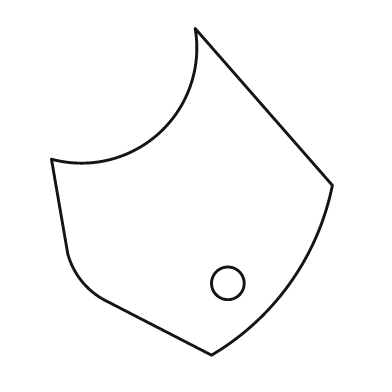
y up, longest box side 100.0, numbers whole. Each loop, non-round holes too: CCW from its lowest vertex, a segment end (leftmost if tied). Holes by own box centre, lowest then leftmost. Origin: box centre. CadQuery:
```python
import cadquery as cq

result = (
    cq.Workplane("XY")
    .moveTo(6.0, -50.0)
    .threePointArc((30.0, -28.0), (43.0, 2.0))
    .lineTo(1.0, 50.0)
    .threePointArc((-10.0, 18.0), (-43.0, 10.0))
    .lineTo(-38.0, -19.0)
    .threePointArc((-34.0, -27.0), (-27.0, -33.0))
    .close()
    .moveTo(11.0, -28.0)
    .circle(5.0)
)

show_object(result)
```